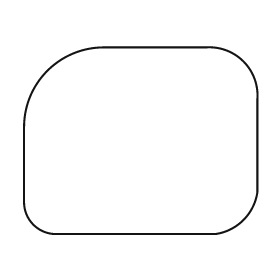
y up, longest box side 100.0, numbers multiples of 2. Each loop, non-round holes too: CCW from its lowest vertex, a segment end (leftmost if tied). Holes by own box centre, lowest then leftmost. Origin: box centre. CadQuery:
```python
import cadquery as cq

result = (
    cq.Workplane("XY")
    .moveTo(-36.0, -40.0)
    .lineTo(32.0, -40.0)
    .threePointArc((44.0, -34.0), (50.0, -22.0))
    .lineTo(50.0, 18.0)
    .threePointArc((44.0, 34.0), (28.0, 40.0))
    .lineTo(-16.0, 40.0)
    .threePointArc((-40.0, 30.0), (-50.0, 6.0))
    .lineTo(-50.0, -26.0)
    .threePointArc((-46.0, -36.0), (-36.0, -40.0))
    .close()
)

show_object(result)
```